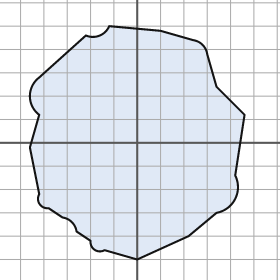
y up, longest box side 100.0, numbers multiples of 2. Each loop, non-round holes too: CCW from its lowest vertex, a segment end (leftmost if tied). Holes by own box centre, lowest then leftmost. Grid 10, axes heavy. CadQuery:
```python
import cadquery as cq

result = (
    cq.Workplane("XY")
    .moveTo(0.0, -50.0)
    .lineTo(22.0, -40.0)
    .lineTo(34.0, -30.0)
    .threePointArc((42.0, -24.0), (42.0, -14.0))
    .lineTo(46.0, 12.0)
    .lineTo(34.0, 24.0)
    .lineTo(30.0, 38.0)
    .threePointArc((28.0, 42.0), (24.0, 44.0))
    .lineTo(10.0, 48.0)
    .lineTo(-12.0, 50.0)
    .threePointArc((-16.0, 46.0), (-22.0, 46.0))
    .lineTo(-42.0, 28.0)
    .threePointArc((-46.0, 20.0), (-42.0, 12.0))
    .lineTo(-46.0, -2.0)
    .lineTo(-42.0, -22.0)
    .threePointArc((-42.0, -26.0), (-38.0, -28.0))
    .lineTo(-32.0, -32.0)
    .threePointArc((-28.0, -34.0), (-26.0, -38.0))
    .lineTo(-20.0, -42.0)
    .threePointArc((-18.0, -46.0), (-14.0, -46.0))
    .close()
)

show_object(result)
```